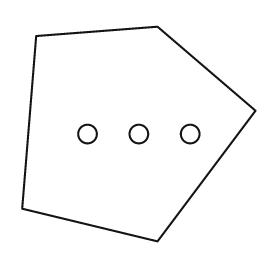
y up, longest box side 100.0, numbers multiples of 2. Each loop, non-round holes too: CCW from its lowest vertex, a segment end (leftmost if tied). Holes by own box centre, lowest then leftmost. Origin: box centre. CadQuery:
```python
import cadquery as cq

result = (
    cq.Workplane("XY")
    .moveTo(8.0, -46.0)
    .lineTo(50.0, 10.0)
    .lineTo(8.0, 46.0)
    .lineTo(-44.0, 42.0)
    .lineTo(-50.0, -32.0)
    .close()
    .moveTo(-22.0, 0.0)
    .circle(4.0)
    .moveTo(0.0, 0.0)
    .circle(4.0)
    .moveTo(22.0, 0.0)
    .circle(4.0)
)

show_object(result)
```